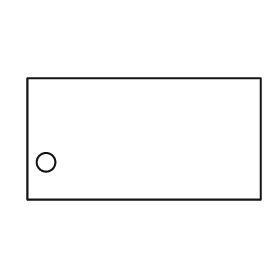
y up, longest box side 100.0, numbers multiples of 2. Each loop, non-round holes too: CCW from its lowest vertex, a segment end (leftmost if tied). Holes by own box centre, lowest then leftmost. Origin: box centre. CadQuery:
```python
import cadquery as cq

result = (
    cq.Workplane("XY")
    .moveTo(-50.0, -26.0)
    .lineTo(50.0, -26.0)
    .lineTo(50.0, 26.0)
    .lineTo(-50.0, 26.0)
    .close()
    .moveTo(-42.0, -10.0)
    .circle(4.0)
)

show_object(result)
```